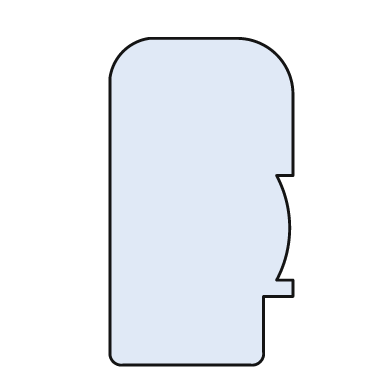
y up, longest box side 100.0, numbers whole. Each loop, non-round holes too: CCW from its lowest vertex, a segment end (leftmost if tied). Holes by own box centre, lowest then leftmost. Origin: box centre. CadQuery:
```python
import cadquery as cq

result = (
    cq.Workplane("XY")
    .moveTo(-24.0, -50.0)
    .lineTo(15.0, -50.0)
    .threePointArc((18.0, -49.0), (19.0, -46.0))
    .lineTo(19.0, -29.0)
    .lineTo(28.0, -29.0)
    .lineTo(28.0, -24.0)
    .lineTo(23.0, -24.0)
    .threePointArc((27.0, -8.0), (23.0, 8.0))
    .lineTo(28.0, 8.0)
    .lineTo(28.0, 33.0)
    .threePointArc((23.0, 45.0), (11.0, 50.0))
    .lineTo(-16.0, 50.0)
    .threePointArc((-24.0, 46.0), (-28.0, 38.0))
    .lineTo(-28.0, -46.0)
    .threePointArc((-27.0, -49.0), (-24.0, -50.0))
    .close()
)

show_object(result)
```